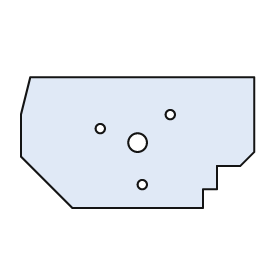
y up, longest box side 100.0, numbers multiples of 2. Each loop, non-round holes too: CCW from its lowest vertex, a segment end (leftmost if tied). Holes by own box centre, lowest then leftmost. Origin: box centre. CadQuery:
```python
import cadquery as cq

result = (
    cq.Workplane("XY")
    .moveTo(-28.0, -28.0)
    .lineTo(28.0, -28.0)
    .lineTo(28.0, -20.0)
    .lineTo(34.0, -20.0)
    .lineTo(34.0, -10.0)
    .lineTo(44.0, -10.0)
    .lineTo(50.0, -4.0)
    .lineTo(50.0, 28.0)
    .lineTo(-46.0, 28.0)
    .lineTo(-50.0, 12.0)
    .lineTo(-50.0, -6.0)
    .close()
    .moveTo(2.0, -18.0)
    .circle(2.0)
    .moveTo(0.0, 0.0)
    .circle(4.0)
    .moveTo(-16.0, 6.0)
    .circle(2.0)
    .moveTo(14.0, 12.0)
    .circle(2.0)
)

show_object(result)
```